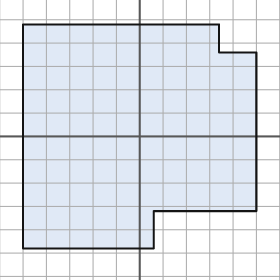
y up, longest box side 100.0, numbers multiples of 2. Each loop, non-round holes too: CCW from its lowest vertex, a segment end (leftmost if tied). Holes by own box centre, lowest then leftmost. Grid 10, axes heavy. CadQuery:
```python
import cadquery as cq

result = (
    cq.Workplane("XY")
    .moveTo(-50.0, -48.0)
    .lineTo(6.0, -48.0)
    .lineTo(6.0, -32.0)
    .lineTo(50.0, -32.0)
    .lineTo(50.0, 36.0)
    .lineTo(34.0, 36.0)
    .lineTo(34.0, 48.0)
    .lineTo(-50.0, 48.0)
    .close()
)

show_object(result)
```